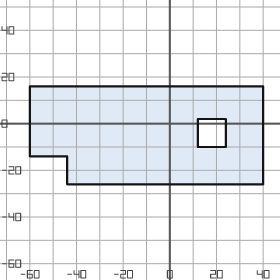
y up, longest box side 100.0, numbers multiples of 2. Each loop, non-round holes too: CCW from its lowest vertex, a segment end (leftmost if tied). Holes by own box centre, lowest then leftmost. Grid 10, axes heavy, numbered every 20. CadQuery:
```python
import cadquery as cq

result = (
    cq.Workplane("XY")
    .moveTo(-44.0, -26.0)
    .lineTo(40.0, -26.0)
    .lineTo(40.0, 16.0)
    .lineTo(-60.0, 16.0)
    .lineTo(-60.0, -14.0)
    .lineTo(-44.0, -14.0)
    .close()
    .moveTo(12.0, -10.0)
    .lineTo(24.0, -10.0)
    .lineTo(24.0, 2.0)
    .lineTo(12.0, 2.0)
    .close()
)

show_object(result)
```